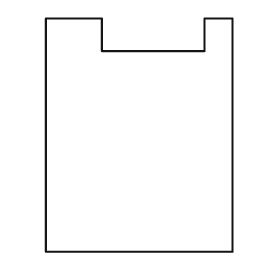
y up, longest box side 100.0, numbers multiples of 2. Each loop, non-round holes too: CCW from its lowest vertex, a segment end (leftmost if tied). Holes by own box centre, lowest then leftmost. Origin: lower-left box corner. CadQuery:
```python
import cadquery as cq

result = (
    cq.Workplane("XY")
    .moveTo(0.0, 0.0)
    .lineTo(80.0, 0.0)
    .lineTo(80.0, 100.0)
    .lineTo(68.0, 100.0)
    .lineTo(68.0, 86.0)
    .lineTo(24.0, 86.0)
    .lineTo(24.0, 100.0)
    .lineTo(0.0, 100.0)
    .close()
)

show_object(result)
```